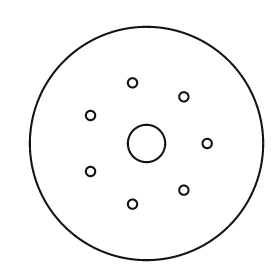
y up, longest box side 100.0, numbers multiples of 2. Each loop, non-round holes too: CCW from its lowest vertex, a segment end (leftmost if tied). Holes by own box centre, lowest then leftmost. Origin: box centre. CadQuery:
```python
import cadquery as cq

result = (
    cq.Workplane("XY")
    .moveTo(0.0, 0.0)
    .circle(50.0)
    .moveTo(-6.0, -26.0)
    .circle(2.0)
    .moveTo(16.0, -20.0)
    .circle(2.0)
    .moveTo(-24.0, -12.0)
    .circle(2.0)
    .moveTo(0.0, 0.0)
    .circle(8.0)
    .moveTo(26.0, 0.0)
    .circle(2.0)
    .moveTo(-24.0, 12.0)
    .circle(2.0)
    .moveTo(16.0, 20.0)
    .circle(2.0)
    .moveTo(-6.0, 26.0)
    .circle(2.0)
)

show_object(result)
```